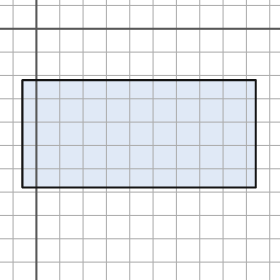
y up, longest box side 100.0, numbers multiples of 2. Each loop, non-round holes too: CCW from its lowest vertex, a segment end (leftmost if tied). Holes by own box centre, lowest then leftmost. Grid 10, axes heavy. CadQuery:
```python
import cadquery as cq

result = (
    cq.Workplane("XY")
    .moveTo(-6.0, -68.0)
    .lineTo(94.0, -68.0)
    .lineTo(94.0, -22.0)
    .lineTo(-6.0, -22.0)
    .close()
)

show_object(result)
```